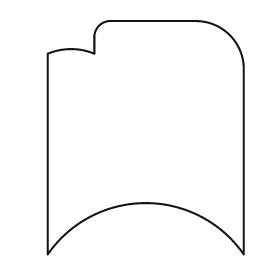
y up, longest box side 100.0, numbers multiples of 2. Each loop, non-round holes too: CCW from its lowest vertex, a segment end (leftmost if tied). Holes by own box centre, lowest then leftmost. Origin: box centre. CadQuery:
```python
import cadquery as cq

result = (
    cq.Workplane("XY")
    .moveTo(-42.0, -50.0)
    .threePointArc((0.0, -28.0), (42.0, -50.0))
    .lineTo(42.0, 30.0)
    .threePointArc((36.0, 44.0), (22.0, 50.0))
    .lineTo(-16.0, 50.0)
    .threePointArc((-20.0, 48.0), (-22.0, 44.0))
    .lineTo(-22.0, 36.0)
    .threePointArc((-32.0, 38.0), (-42.0, 36.0))
    .close()
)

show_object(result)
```